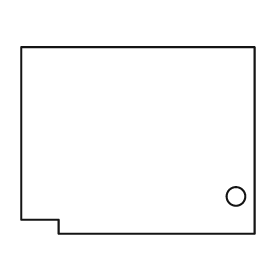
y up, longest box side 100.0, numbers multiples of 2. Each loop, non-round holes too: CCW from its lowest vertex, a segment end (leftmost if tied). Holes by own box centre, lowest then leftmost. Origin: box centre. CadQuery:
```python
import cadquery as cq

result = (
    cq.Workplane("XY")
    .moveTo(-34.0, -40.0)
    .lineTo(50.0, -40.0)
    .lineTo(50.0, 40.0)
    .lineTo(-50.0, 40.0)
    .lineTo(-50.0, -34.0)
    .lineTo(-34.0, -34.0)
    .close()
    .moveTo(42.0, -24.0)
    .circle(4.0)
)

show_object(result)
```